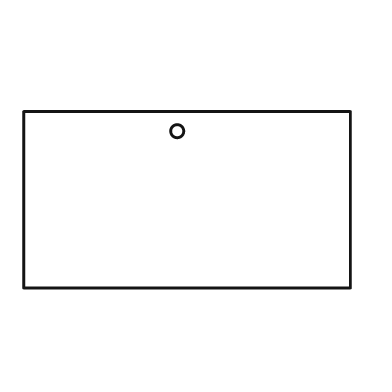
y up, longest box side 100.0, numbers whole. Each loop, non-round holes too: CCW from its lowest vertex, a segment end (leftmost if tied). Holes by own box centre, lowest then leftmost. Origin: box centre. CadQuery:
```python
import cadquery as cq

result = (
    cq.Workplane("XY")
    .moveTo(-50.0, -27.0)
    .lineTo(50.0, -27.0)
    .lineTo(50.0, 27.0)
    .lineTo(-50.0, 27.0)
    .close()
    .moveTo(-3.0, 21.0)
    .circle(2.0)
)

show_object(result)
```